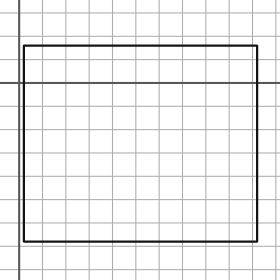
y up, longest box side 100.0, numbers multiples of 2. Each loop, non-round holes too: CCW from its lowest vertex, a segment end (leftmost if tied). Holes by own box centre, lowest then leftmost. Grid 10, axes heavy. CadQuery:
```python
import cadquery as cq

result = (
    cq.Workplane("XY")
    .moveTo(2.0, -68.0)
    .lineTo(102.0, -68.0)
    .lineTo(102.0, 16.0)
    .lineTo(2.0, 16.0)
    .close()
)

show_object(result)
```